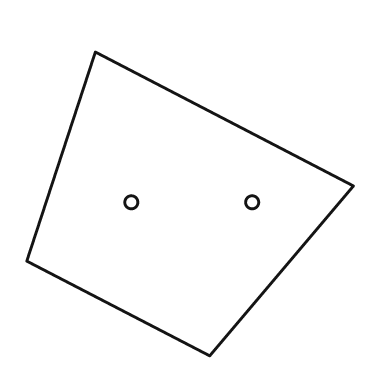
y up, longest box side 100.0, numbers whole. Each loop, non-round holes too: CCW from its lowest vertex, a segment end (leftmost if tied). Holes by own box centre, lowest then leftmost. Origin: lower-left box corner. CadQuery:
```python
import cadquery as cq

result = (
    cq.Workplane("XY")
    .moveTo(56.0, 0.0)
    .lineTo(100.0, 52.0)
    .lineTo(21.0, 93.0)
    .lineTo(0.0, 29.0)
    .close()
    .moveTo(32.0, 47.0)
    .circle(2.0)
    .moveTo(69.0, 47.0)
    .circle(2.0)
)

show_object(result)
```